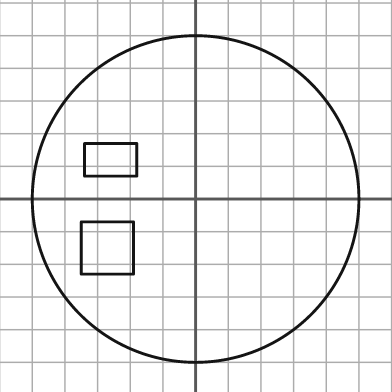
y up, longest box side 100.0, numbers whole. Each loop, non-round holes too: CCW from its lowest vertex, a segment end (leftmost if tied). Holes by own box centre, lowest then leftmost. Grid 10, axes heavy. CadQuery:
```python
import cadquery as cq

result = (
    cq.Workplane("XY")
    .moveTo(0.0, 0.0)
    .circle(50.0)
    .moveTo(-35.0, -23.0)
    .lineTo(-19.0, -23.0)
    .lineTo(-19.0, -7.0)
    .lineTo(-35.0, -7.0)
    .close()
    .moveTo(-34.0, 7.0)
    .lineTo(-18.0, 7.0)
    .lineTo(-18.0, 17.0)
    .lineTo(-34.0, 17.0)
    .close()
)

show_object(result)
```